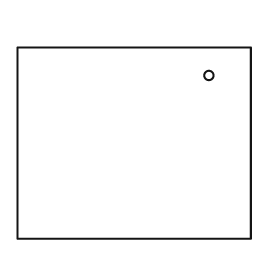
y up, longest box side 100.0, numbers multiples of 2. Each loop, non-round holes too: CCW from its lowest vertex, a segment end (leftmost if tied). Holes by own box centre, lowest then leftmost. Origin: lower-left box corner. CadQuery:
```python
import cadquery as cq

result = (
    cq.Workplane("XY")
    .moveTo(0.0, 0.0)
    .lineTo(100.0, 0.0)
    .lineTo(100.0, 82.0)
    .lineTo(0.0, 82.0)
    .close()
    .moveTo(82.0, 70.0)
    .circle(2.0)
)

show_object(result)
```